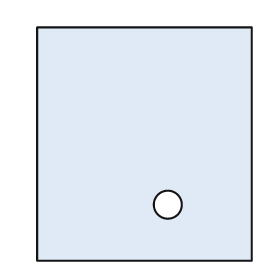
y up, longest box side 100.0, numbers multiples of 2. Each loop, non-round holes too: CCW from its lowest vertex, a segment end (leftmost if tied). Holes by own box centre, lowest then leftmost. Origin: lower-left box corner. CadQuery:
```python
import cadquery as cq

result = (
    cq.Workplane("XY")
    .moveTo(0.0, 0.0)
    .lineTo(92.0, 0.0)
    .lineTo(92.0, 100.0)
    .lineTo(0.0, 100.0)
    .close()
    .moveTo(56.0, 24.0)
    .circle(6.0)
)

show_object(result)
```